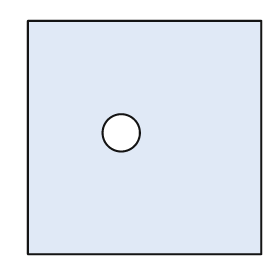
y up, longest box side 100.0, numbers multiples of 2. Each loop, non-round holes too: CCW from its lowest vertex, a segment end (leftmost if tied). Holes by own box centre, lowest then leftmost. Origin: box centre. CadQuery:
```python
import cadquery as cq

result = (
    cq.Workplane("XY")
    .moveTo(-50.0, -50.0)
    .lineTo(50.0, -50.0)
    .lineTo(50.0, 50.0)
    .lineTo(-50.0, 50.0)
    .close()
    .moveTo(-10.0, 2.0)
    .circle(8.0)
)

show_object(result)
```